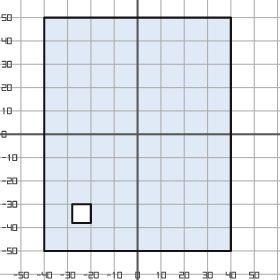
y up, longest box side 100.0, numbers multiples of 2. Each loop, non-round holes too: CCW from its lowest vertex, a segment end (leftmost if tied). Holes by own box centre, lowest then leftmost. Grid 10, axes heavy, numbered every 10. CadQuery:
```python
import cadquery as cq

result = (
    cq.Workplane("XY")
    .moveTo(-40.0, -50.0)
    .lineTo(40.0, -50.0)
    .lineTo(40.0, 50.0)
    .lineTo(-40.0, 50.0)
    .close()
    .moveTo(-28.0, -38.0)
    .lineTo(-20.0, -38.0)
    .lineTo(-20.0, -30.0)
    .lineTo(-28.0, -30.0)
    .close()
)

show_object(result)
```